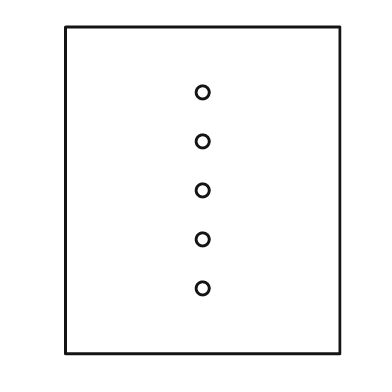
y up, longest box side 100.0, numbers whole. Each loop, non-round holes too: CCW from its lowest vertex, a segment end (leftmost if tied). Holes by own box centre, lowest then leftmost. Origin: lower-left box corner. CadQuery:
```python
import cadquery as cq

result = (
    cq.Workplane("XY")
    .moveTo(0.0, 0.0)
    .lineTo(84.0, 0.0)
    .lineTo(84.0, 100.0)
    .lineTo(0.0, 100.0)
    .close()
    .moveTo(42.0, 20.0)
    .circle(2.0)
    .moveTo(42.0, 35.0)
    .circle(2.0)
    .moveTo(42.0, 50.0)
    .circle(2.0)
    .moveTo(42.0, 65.0)
    .circle(2.0)
    .moveTo(42.0, 80.0)
    .circle(2.0)
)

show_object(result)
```